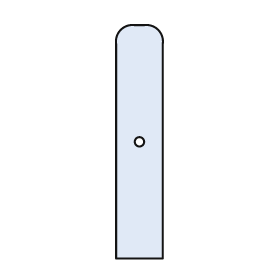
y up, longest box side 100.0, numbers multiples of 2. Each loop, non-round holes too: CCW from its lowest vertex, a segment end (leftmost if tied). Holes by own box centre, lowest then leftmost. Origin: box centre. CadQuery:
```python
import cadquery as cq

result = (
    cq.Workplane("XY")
    .moveTo(-10.0, -50.0)
    .lineTo(10.0, -50.0)
    .lineTo(10.0, 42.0)
    .threePointArc((8.0, 48.0), (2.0, 50.0))
    .lineTo(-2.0, 50.0)
    .threePointArc((-8.0, 48.0), (-10.0, 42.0))
    .close()
    .moveTo(0.0, 0.0)
    .circle(2.0)
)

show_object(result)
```